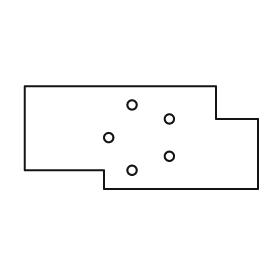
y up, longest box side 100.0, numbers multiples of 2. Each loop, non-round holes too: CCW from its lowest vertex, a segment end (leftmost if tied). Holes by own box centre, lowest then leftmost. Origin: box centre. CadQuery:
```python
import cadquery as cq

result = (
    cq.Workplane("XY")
    .moveTo(-16.0, -22.0)
    .lineTo(50.0, -22.0)
    .lineTo(50.0, 8.0)
    .lineTo(32.0, 8.0)
    .lineTo(32.0, 22.0)
    .lineTo(-50.0, 22.0)
    .lineTo(-50.0, -14.0)
    .lineTo(-16.0, -14.0)
    .close()
    .moveTo(-4.0, -14.0)
    .circle(2.0)
    .moveTo(12.0, -8.0)
    .circle(2.0)
    .moveTo(-14.0, 0.0)
    .circle(2.0)
    .moveTo(12.0, 8.0)
    .circle(2.0)
    .moveTo(-4.0, 14.0)
    .circle(2.0)
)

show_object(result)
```